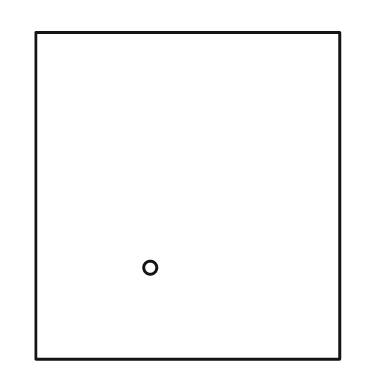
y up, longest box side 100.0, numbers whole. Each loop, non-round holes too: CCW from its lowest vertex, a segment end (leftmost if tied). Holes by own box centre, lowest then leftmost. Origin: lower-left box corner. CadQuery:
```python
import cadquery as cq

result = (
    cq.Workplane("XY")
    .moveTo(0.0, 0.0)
    .lineTo(93.0, 0.0)
    .lineTo(93.0, 100.0)
    .lineTo(0.0, 100.0)
    .close()
    .moveTo(35.0, 28.0)
    .circle(2.0)
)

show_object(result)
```